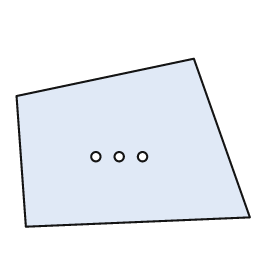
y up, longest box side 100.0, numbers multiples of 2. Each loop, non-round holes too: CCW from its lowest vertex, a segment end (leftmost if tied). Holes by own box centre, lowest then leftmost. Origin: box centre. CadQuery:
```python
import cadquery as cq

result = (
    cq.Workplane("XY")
    .moveTo(-46.0, -36.0)
    .lineTo(50.0, -32.0)
    .lineTo(26.0, 36.0)
    .lineTo(-50.0, 20.0)
    .close()
    .moveTo(-16.0, -6.0)
    .circle(2.0)
    .moveTo(-6.0, -6.0)
    .circle(2.0)
    .moveTo(4.0, -6.0)
    .circle(2.0)
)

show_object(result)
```